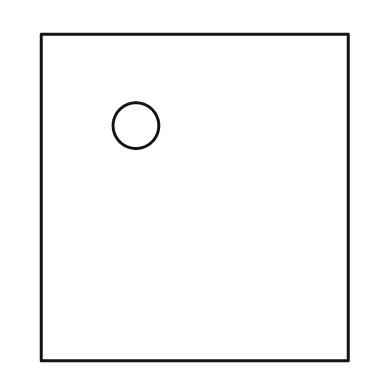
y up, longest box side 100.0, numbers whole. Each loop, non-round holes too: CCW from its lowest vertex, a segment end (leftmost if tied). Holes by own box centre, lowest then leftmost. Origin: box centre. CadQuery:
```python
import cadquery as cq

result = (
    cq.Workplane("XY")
    .moveTo(-47.0, -50.0)
    .lineTo(47.0, -50.0)
    .lineTo(47.0, 50.0)
    .lineTo(-47.0, 50.0)
    .close()
    .moveTo(-18.0, 22.0)
    .circle(7.0)
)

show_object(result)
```